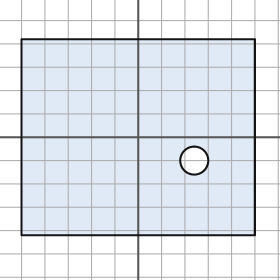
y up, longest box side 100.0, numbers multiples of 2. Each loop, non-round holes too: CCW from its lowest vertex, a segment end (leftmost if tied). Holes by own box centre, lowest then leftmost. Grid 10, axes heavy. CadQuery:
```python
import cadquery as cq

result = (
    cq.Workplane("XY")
    .moveTo(-50.0, -42.0)
    .lineTo(50.0, -42.0)
    .lineTo(50.0, 42.0)
    .lineTo(-50.0, 42.0)
    .close()
    .moveTo(24.0, -10.0)
    .circle(6.0)
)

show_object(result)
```